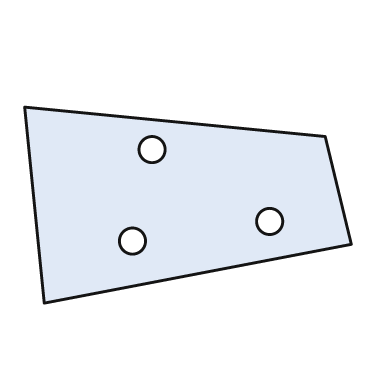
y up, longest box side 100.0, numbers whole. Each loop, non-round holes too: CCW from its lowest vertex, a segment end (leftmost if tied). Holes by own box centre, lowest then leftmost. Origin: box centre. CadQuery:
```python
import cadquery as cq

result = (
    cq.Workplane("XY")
    .moveTo(-44.0, -30.0)
    .lineTo(50.0, -12.0)
    .lineTo(42.0, 21.0)
    .lineTo(-50.0, 30.0)
    .close()
    .moveTo(-17.0, -11.0)
    .circle(4.0)
    .moveTo(25.0, -5.0)
    .circle(4.0)
    .moveTo(-11.0, 17.0)
    .circle(4.0)
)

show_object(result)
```